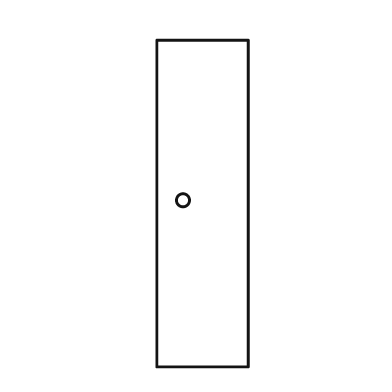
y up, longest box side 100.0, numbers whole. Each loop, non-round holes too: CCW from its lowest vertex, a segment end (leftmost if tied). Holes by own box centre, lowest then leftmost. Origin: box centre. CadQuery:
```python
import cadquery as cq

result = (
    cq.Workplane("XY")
    .moveTo(-14.0, -50.0)
    .lineTo(14.0, -50.0)
    .lineTo(14.0, 50.0)
    .lineTo(-14.0, 50.0)
    .close()
    .moveTo(-6.0, 1.0)
    .circle(2.0)
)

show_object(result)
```